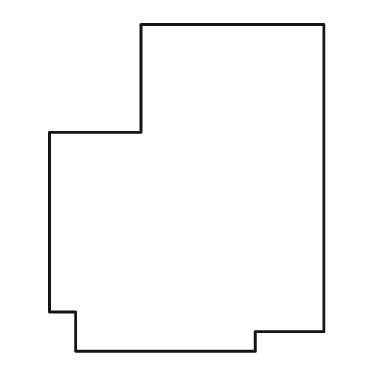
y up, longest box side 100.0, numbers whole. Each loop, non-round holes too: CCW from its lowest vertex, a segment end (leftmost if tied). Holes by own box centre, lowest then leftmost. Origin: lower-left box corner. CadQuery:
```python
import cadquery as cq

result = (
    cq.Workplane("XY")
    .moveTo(8.0, 0.0)
    .lineTo(63.0, 0.0)
    .lineTo(63.0, 6.0)
    .lineTo(84.0, 6.0)
    .lineTo(84.0, 100.0)
    .lineTo(28.0, 100.0)
    .lineTo(28.0, 67.0)
    .lineTo(0.0, 67.0)
    .lineTo(0.0, 12.0)
    .lineTo(8.0, 12.0)
    .close()
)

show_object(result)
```